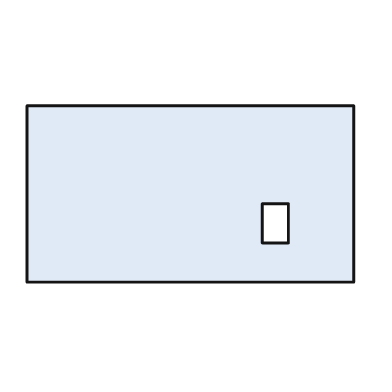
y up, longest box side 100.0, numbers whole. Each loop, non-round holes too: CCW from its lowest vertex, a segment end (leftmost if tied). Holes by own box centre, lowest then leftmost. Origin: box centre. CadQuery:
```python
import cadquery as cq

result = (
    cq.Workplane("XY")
    .moveTo(-50.0, -27.0)
    .lineTo(50.0, -27.0)
    .lineTo(50.0, 27.0)
    .lineTo(-50.0, 27.0)
    .close()
    .moveTo(22.0, -15.0)
    .lineTo(30.0, -15.0)
    .lineTo(30.0, -3.0)
    .lineTo(22.0, -3.0)
    .close()
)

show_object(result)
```